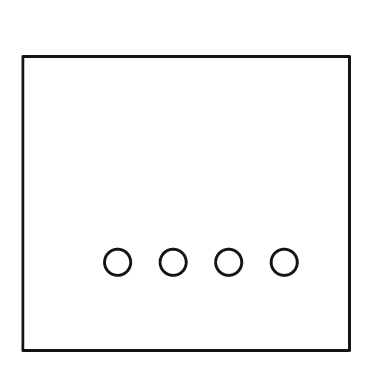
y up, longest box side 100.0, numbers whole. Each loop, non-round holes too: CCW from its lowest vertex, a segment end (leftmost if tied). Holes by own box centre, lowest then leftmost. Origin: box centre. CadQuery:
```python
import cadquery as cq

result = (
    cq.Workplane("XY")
    .moveTo(-50.0, -45.0)
    .lineTo(50.0, -45.0)
    .lineTo(50.0, 45.0)
    .lineTo(-50.0, 45.0)
    .close()
    .moveTo(-21.0, -18.0)
    .circle(4.0)
    .moveTo(-4.0, -18.0)
    .circle(4.0)
    .moveTo(13.0, -18.0)
    .circle(4.0)
    .moveTo(30.0, -18.0)
    .circle(4.0)
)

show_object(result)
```